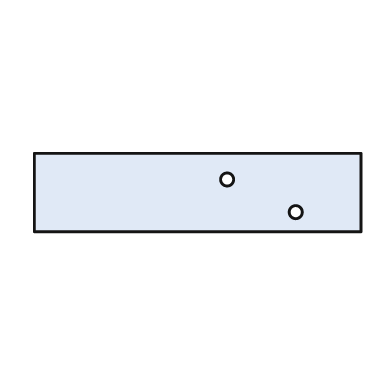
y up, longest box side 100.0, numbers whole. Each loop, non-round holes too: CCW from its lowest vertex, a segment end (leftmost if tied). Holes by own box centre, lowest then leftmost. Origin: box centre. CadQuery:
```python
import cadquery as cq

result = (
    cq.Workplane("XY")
    .moveTo(-50.0, -12.0)
    .lineTo(50.0, -12.0)
    .lineTo(50.0, 12.0)
    .lineTo(-50.0, 12.0)
    .close()
    .moveTo(30.0, -6.0)
    .circle(2.0)
    .moveTo(9.0, 4.0)
    .circle(2.0)
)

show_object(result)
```